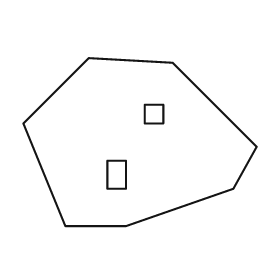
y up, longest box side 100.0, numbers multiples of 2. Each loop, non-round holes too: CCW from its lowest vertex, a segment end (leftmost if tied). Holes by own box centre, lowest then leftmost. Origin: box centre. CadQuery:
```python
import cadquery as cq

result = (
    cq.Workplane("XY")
    .moveTo(-32.0, -36.0)
    .lineTo(-6.0, -36.0)
    .lineTo(40.0, -20.0)
    .lineTo(50.0, -2.0)
    .lineTo(14.0, 34.0)
    .lineTo(-22.0, 36.0)
    .lineTo(-50.0, 8.0)
    .close()
    .moveTo(-14.0, -20.0)
    .lineTo(-6.0, -20.0)
    .lineTo(-6.0, -8.0)
    .lineTo(-14.0, -8.0)
    .close()
    .moveTo(2.0, 8.0)
    .lineTo(10.0, 8.0)
    .lineTo(10.0, 16.0)
    .lineTo(2.0, 16.0)
    .close()
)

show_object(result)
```